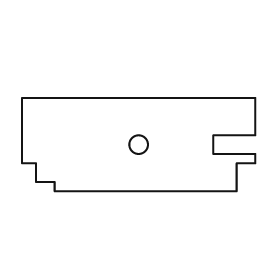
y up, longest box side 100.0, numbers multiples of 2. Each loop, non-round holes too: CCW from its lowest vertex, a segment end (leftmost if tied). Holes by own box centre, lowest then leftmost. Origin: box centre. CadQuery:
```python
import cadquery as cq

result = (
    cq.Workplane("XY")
    .moveTo(-36.0, -20.0)
    .lineTo(42.0, -20.0)
    .lineTo(42.0, -8.0)
    .lineTo(50.0, -8.0)
    .lineTo(50.0, -4.0)
    .lineTo(32.0, -4.0)
    .lineTo(32.0, 4.0)
    .lineTo(50.0, 4.0)
    .lineTo(50.0, 20.0)
    .lineTo(-50.0, 20.0)
    .lineTo(-50.0, -8.0)
    .lineTo(-44.0, -8.0)
    .lineTo(-44.0, -16.0)
    .lineTo(-36.0, -16.0)
    .close()
    .moveTo(0.0, 0.0)
    .circle(4.0)
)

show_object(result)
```